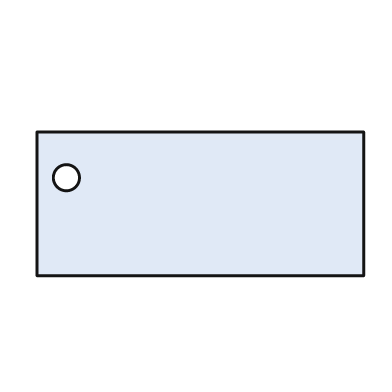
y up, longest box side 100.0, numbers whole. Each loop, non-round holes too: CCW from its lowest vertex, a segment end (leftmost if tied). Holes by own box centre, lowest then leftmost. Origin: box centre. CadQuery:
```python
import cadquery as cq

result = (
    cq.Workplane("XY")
    .moveTo(-50.0, -22.0)
    .lineTo(50.0, -22.0)
    .lineTo(50.0, 22.0)
    .lineTo(-50.0, 22.0)
    .close()
    .moveTo(-41.0, 8.0)
    .circle(4.0)
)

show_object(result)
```